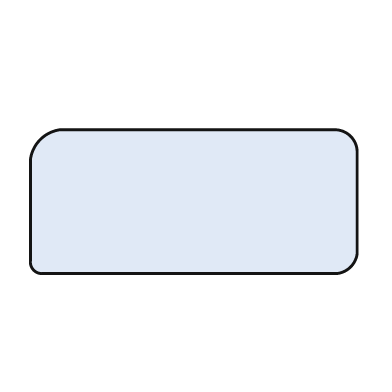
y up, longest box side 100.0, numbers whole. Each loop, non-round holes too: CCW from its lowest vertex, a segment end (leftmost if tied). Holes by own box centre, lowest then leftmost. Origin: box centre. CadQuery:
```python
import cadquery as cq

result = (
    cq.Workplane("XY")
    .moveTo(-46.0, -22.0)
    .lineTo(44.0, -22.0)
    .threePointArc((48.0, -20.0), (50.0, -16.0))
    .lineTo(50.0, 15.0)
    .threePointArc((48.0, 20.0), (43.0, 22.0))
    .lineTo(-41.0, 22.0)
    .threePointArc((-47.0, 19.0), (-50.0, 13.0))
    .lineTo(-50.0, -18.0)
    .threePointArc((-49.0, -21.0), (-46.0, -22.0))
    .close()
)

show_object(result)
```